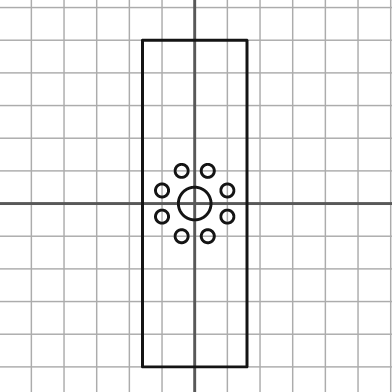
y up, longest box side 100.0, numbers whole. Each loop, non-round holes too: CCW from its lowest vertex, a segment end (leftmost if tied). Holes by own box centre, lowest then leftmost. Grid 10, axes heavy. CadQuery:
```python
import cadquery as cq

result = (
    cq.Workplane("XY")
    .moveTo(-16.0, -50.0)
    .lineTo(16.0, -50.0)
    .lineTo(16.0, 50.0)
    .lineTo(-16.0, 50.0)
    .close()
    .moveTo(-4.0, -10.0)
    .circle(2.0)
    .moveTo(4.0, -10.0)
    .circle(2.0)
    .moveTo(-10.0, -4.0)
    .circle(2.0)
    .moveTo(10.0, -4.0)
    .circle(2.0)
    .moveTo(0.0, 0.0)
    .circle(5.0)
    .moveTo(-10.0, 4.0)
    .circle(2.0)
    .moveTo(10.0, 4.0)
    .circle(2.0)
    .moveTo(-4.0, 10.0)
    .circle(2.0)
    .moveTo(4.0, 10.0)
    .circle(2.0)
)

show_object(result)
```